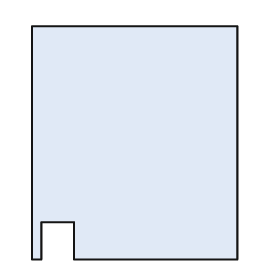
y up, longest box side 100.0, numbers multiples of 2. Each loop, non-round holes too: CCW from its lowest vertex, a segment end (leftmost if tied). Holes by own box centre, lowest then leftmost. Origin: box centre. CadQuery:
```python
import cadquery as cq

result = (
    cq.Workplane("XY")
    .moveTo(-44.0, -50.0)
    .lineTo(-40.0, -50.0)
    .lineTo(-40.0, -34.0)
    .lineTo(-26.0, -34.0)
    .lineTo(-26.0, -50.0)
    .lineTo(44.0, -50.0)
    .lineTo(44.0, 50.0)
    .lineTo(-44.0, 50.0)
    .close()
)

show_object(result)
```